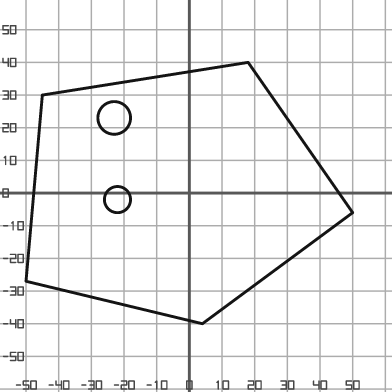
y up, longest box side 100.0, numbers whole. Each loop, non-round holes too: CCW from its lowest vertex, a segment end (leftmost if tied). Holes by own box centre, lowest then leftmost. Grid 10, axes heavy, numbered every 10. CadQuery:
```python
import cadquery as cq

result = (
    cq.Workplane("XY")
    .moveTo(4.0, -40.0)
    .lineTo(50.0, -6.0)
    .lineTo(18.0, 40.0)
    .lineTo(-45.0, 30.0)
    .lineTo(-50.0, -27.0)
    .close()
    .moveTo(-22.0, -2.0)
    .circle(4.0)
    .moveTo(-23.0, 23.0)
    .circle(5.0)
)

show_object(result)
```